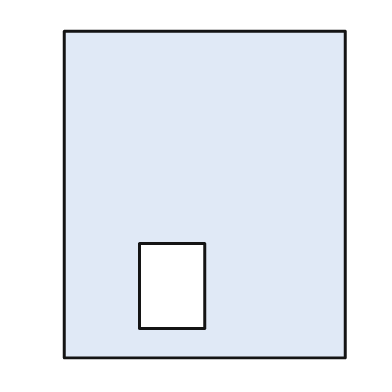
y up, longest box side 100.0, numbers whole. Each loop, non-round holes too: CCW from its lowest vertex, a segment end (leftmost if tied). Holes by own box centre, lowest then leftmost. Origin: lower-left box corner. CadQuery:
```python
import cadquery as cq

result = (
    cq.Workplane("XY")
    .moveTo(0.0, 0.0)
    .lineTo(86.0, 0.0)
    .lineTo(86.0, 100.0)
    .lineTo(0.0, 100.0)
    .close()
    .moveTo(23.0, 9.0)
    .lineTo(43.0, 9.0)
    .lineTo(43.0, 35.0)
    .lineTo(23.0, 35.0)
    .close()
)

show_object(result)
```